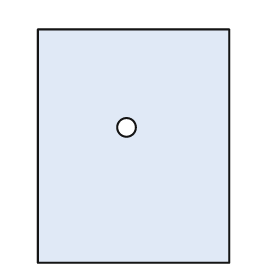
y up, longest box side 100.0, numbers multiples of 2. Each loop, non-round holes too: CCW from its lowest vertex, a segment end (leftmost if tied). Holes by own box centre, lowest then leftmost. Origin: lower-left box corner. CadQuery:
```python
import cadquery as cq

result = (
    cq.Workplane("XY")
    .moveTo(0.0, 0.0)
    .lineTo(82.0, 0.0)
    .lineTo(82.0, 100.0)
    .lineTo(0.0, 100.0)
    .close()
    .moveTo(38.0, 58.0)
    .circle(4.0)
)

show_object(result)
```